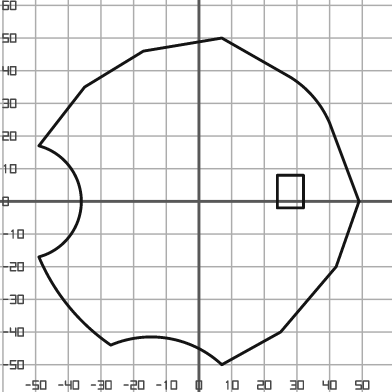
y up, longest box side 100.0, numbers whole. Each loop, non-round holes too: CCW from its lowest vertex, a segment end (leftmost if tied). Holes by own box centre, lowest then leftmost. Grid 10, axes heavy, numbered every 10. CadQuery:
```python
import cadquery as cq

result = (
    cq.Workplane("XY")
    .moveTo(7.0, -50.0)
    .lineTo(25.0, -40.0)
    .lineTo(42.0, -20.0)
    .lineTo(49.0, 0.0)
    .lineTo(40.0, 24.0)
    .threePointArc((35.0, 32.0), (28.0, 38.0))
    .lineTo(7.0, 50.0)
    .lineTo(-17.0, 46.0)
    .lineTo(-35.0, 35.0)
    .lineTo(-49.0, 17.0)
    .threePointArc((-36.0, 0.0), (-49.0, -17.0))
    .threePointArc((-40.0, -32.0), (-27.0, -44.0))
    .threePointArc((-9.0, -42.0), (7.0, -50.0))
    .close()
    .moveTo(24.0, -2.0)
    .lineTo(32.0, -2.0)
    .lineTo(32.0, 8.0)
    .lineTo(24.0, 8.0)
    .close()
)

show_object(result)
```